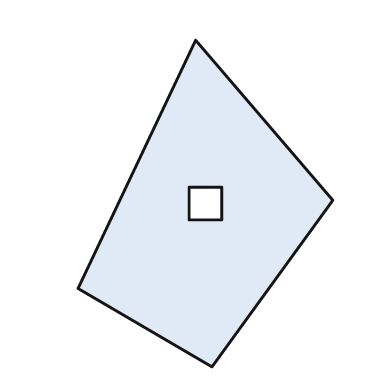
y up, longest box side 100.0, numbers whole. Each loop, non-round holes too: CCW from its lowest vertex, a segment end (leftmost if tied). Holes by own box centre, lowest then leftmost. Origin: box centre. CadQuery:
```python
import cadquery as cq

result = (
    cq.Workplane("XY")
    .moveTo(2.0, -50.0)
    .lineTo(39.0, 1.0)
    .lineTo(-3.0, 50.0)
    .lineTo(-39.0, -26.0)
    .close()
    .moveTo(-5.0, -5.0)
    .lineTo(5.0, -5.0)
    .lineTo(5.0, 5.0)
    .lineTo(-5.0, 5.0)
    .close()
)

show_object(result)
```